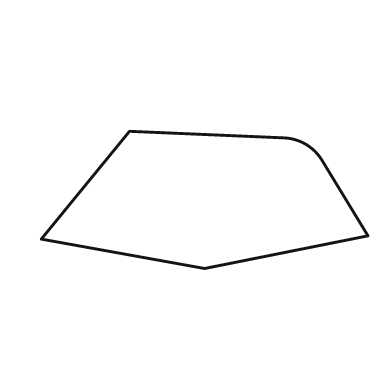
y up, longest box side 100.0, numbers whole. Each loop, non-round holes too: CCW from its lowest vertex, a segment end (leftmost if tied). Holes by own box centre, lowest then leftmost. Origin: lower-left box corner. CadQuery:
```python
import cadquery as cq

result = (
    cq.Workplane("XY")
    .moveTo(50.0, 0.0)
    .lineTo(100.0, 10.0)
    .lineTo(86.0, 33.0)
    .threePointArc((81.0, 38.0), (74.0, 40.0))
    .lineTo(27.0, 42.0)
    .lineTo(0.0, 9.0)
    .close()
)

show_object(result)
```